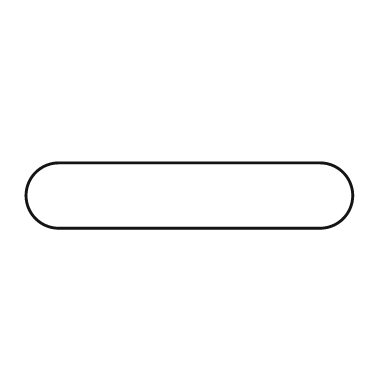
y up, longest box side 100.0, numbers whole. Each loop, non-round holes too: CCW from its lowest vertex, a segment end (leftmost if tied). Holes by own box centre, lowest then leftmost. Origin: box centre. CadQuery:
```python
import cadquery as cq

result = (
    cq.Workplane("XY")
    .moveTo(-40.0, -10.0)
    .lineTo(40.0, -10.0)
    .threePointArc((50.0, 0.0), (40.0, 10.0))
    .lineTo(-40.0, 10.0)
    .threePointArc((-50.0, 0.0), (-40.0, -10.0))
    .close()
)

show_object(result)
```